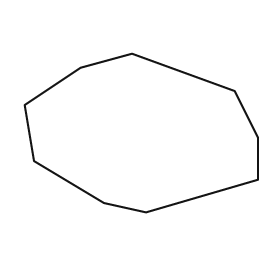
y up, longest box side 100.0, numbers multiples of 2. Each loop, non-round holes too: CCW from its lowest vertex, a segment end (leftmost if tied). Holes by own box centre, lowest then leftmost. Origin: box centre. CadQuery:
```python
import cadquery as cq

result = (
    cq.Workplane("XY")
    .moveTo(2.0, -34.0)
    .lineTo(50.0, -20.0)
    .lineTo(50.0, -2.0)
    .lineTo(40.0, 18.0)
    .lineTo(-4.0, 34.0)
    .lineTo(-26.0, 28.0)
    .lineTo(-50.0, 12.0)
    .lineTo(-46.0, -12.0)
    .lineTo(-16.0, -30.0)
    .close()
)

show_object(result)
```